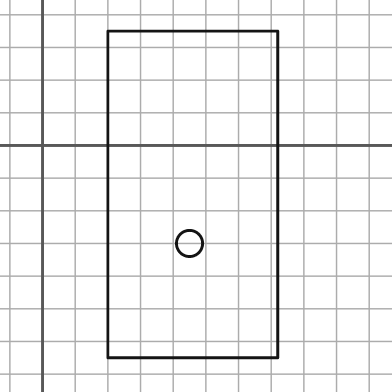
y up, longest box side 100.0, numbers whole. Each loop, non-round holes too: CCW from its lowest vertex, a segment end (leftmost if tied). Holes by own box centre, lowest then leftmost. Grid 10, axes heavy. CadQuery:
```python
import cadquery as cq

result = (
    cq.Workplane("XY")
    .moveTo(20.0, -65.0)
    .lineTo(72.0, -65.0)
    .lineTo(72.0, 35.0)
    .lineTo(20.0, 35.0)
    .close()
    .moveTo(45.0, -30.0)
    .circle(4.0)
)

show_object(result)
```